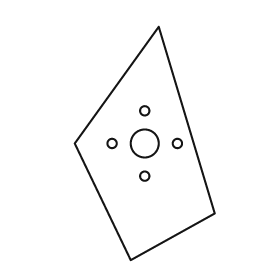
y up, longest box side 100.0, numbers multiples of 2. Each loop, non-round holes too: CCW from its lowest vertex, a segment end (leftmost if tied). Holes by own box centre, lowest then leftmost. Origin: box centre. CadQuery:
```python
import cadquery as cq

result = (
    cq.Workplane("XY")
    .moveTo(-6.0, -50.0)
    .lineTo(30.0, -30.0)
    .lineTo(6.0, 50.0)
    .lineTo(-30.0, 0.0)
    .close()
    .moveTo(0.0, -14.0)
    .circle(2.0)
    .moveTo(-14.0, 0.0)
    .circle(2.0)
    .moveTo(0.0, 0.0)
    .circle(6.0)
    .moveTo(14.0, 0.0)
    .circle(2.0)
    .moveTo(0.0, 14.0)
    .circle(2.0)
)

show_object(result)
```